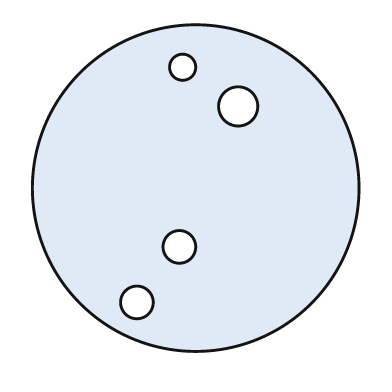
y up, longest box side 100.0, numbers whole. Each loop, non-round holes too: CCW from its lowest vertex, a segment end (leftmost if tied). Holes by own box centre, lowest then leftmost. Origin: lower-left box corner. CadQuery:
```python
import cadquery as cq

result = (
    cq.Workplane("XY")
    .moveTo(50.0, 50.0)
    .circle(50.0)
    .moveTo(32.0, 15.0)
    .circle(5.0)
    .moveTo(45.0, 32.0)
    .circle(5.0)
    .moveTo(63.0, 75.0)
    .circle(6.0)
    .moveTo(46.0, 87.0)
    .circle(4.0)
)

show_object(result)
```